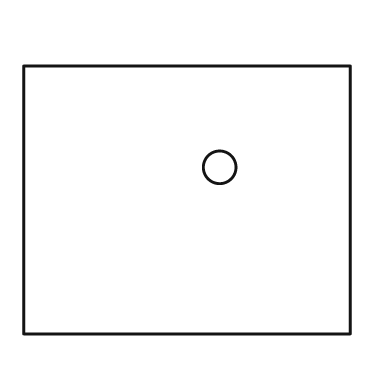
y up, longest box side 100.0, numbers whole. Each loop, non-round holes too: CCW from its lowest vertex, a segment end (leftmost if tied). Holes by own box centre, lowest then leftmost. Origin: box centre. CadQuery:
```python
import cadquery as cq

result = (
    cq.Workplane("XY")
    .moveTo(-50.0, -41.0)
    .lineTo(50.0, -41.0)
    .lineTo(50.0, 41.0)
    .lineTo(-50.0, 41.0)
    .close()
    .moveTo(10.0, 10.0)
    .circle(5.0)
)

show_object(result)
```